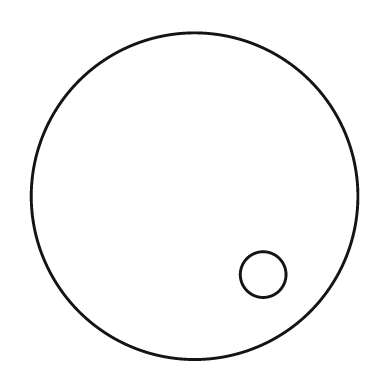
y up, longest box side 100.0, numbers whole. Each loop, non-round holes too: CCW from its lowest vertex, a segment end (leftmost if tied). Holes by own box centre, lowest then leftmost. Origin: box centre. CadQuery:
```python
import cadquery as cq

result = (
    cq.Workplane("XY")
    .moveTo(0.0, 0.0)
    .circle(50.0)
    .moveTo(21.0, -24.0)
    .circle(7.0)
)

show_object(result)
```